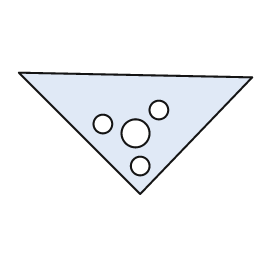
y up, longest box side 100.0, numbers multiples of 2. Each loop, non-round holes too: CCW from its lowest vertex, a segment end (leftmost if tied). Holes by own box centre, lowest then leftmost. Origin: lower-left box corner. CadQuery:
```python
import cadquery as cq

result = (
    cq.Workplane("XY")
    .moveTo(52.0, 0.0)
    .lineTo(100.0, 50.0)
    .lineTo(0.0, 52.0)
    .close()
    .moveTo(52.0, 12.0)
    .circle(4.0)
    .moveTo(50.0, 26.0)
    .circle(6.0)
    .moveTo(36.0, 30.0)
    .circle(4.0)
    .moveTo(60.0, 36.0)
    .circle(4.0)
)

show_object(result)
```